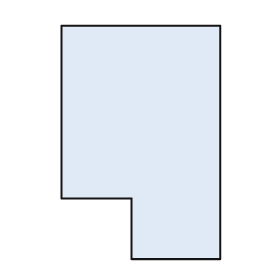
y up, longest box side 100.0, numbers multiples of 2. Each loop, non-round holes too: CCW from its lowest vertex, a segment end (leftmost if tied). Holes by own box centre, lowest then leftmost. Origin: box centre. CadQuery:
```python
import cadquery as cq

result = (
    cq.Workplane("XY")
    .moveTo(-4.0, -50.0)
    .lineTo(34.0, -50.0)
    .lineTo(34.0, 50.0)
    .lineTo(-34.0, 50.0)
    .lineTo(-34.0, -24.0)
    .lineTo(-4.0, -24.0)
    .close()
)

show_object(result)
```